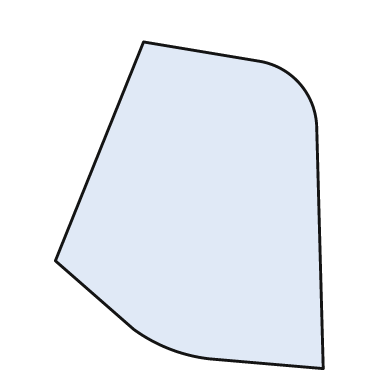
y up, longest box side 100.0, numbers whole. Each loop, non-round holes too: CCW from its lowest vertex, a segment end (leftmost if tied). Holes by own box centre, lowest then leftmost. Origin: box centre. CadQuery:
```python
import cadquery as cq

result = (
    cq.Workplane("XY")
    .moveTo(41.0, -50.0)
    .lineTo(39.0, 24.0)
    .threePointArc((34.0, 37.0), (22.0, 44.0))
    .lineTo(-14.0, 50.0)
    .lineTo(-41.0, -17.0)
    .lineTo(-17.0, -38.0)
    .threePointArc((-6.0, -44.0), (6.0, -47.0))
    .close()
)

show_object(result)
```